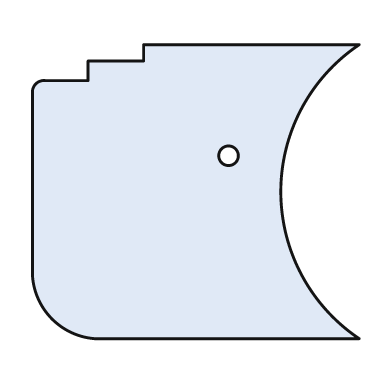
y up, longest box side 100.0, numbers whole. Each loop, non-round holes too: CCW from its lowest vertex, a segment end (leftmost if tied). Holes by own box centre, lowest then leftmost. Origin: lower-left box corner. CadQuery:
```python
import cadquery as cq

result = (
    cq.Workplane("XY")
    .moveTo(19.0, 0.0)
    .lineTo(100.0, 0.0)
    .threePointArc((76.0, 45.0), (100.0, 90.0))
    .lineTo(34.0, 90.0)
    .lineTo(34.0, 85.0)
    .lineTo(17.0, 85.0)
    .lineTo(17.0, 79.0)
    .lineTo(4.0, 79.0)
    .threePointArc((1.0, 78.0), (0.0, 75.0))
    .lineTo(0.0, 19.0)
    .threePointArc((6.0, 6.0), (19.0, 0.0))
    .close()
    .moveTo(60.0, 56.0)
    .circle(3.0)
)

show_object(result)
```